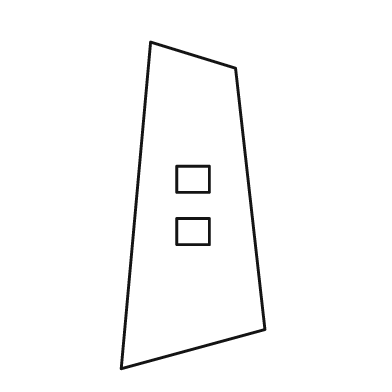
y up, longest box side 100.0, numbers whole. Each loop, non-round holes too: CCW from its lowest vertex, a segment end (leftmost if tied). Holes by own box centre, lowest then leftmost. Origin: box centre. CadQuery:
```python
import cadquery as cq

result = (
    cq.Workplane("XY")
    .moveTo(-22.0, -50.0)
    .lineTo(22.0, -38.0)
    .lineTo(13.0, 42.0)
    .lineTo(-13.0, 50.0)
    .close()
    .moveTo(-5.0, -12.0)
    .lineTo(5.0, -12.0)
    .lineTo(5.0, -4.0)
    .lineTo(-5.0, -4.0)
    .close()
    .moveTo(-5.0, 4.0)
    .lineTo(5.0, 4.0)
    .lineTo(5.0, 12.0)
    .lineTo(-5.0, 12.0)
    .close()
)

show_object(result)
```